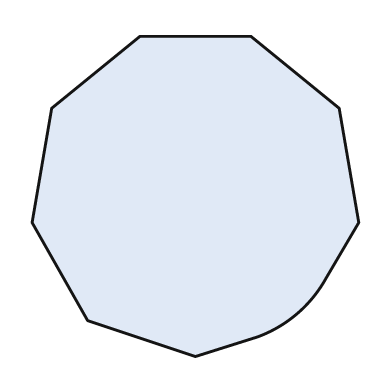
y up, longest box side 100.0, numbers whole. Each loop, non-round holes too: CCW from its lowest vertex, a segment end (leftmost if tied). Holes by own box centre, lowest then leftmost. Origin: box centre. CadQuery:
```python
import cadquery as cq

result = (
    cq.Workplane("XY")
    .moveTo(0.0, -49.0)
    .lineTo(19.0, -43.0)
    .threePointArc((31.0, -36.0), (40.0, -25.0))
    .lineTo(50.0, -8.0)
    .lineTo(44.0, 27.0)
    .lineTo(17.0, 49.0)
    .lineTo(-17.0, 49.0)
    .lineTo(-44.0, 27.0)
    .lineTo(-50.0, -8.0)
    .lineTo(-33.0, -38.0)
    .close()
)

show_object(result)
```